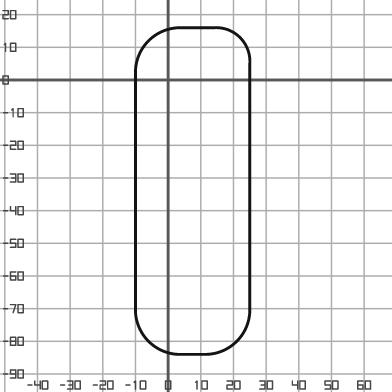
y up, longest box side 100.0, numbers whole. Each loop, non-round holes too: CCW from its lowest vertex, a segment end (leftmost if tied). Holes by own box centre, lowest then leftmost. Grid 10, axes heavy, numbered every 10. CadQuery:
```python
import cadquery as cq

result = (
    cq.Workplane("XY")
    .moveTo(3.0, -84.0)
    .lineTo(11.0, -84.0)
    .threePointArc((21.0, -80.0), (25.0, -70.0))
    .lineTo(25.0, 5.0)
    .threePointArc((22.0, 13.0), (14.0, 16.0))
    .lineTo(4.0, 16.0)
    .threePointArc((-6.0, 12.0), (-10.0, 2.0))
    .lineTo(-10.0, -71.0)
    .threePointArc((-6.0, -80.0), (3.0, -84.0))
    .close()
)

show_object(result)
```